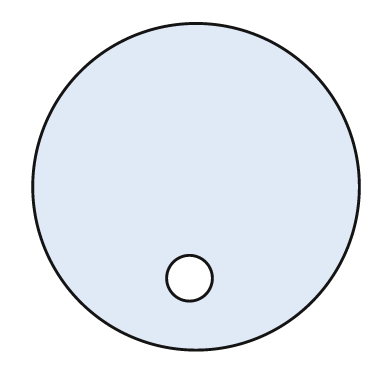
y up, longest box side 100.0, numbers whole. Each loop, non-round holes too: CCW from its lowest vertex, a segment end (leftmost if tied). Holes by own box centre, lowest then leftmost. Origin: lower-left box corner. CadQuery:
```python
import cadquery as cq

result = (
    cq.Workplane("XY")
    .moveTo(50.0, 50.0)
    .circle(50.0)
    .moveTo(48.0, 22.0)
    .circle(7.0)
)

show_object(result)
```